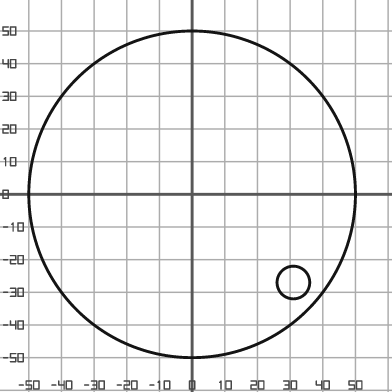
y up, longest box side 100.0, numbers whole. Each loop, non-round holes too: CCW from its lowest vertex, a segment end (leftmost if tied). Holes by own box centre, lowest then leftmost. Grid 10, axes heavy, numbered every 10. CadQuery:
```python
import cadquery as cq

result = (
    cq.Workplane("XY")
    .moveTo(0.0, 0.0)
    .circle(50.0)
    .moveTo(31.0, -27.0)
    .circle(5.0)
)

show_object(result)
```